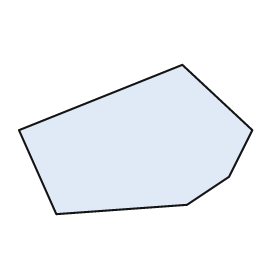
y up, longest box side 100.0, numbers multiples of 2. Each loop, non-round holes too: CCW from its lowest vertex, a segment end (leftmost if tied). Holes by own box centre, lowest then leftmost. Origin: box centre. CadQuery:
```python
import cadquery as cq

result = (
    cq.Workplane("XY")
    .moveTo(-34.0, -32.0)
    .lineTo(22.0, -28.0)
    .lineTo(40.0, -16.0)
    .lineTo(50.0, 4.0)
    .lineTo(20.0, 32.0)
    .lineTo(-50.0, 4.0)
    .close()
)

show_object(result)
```